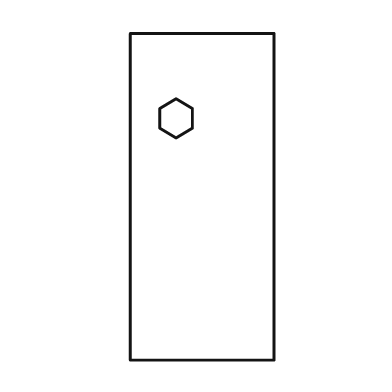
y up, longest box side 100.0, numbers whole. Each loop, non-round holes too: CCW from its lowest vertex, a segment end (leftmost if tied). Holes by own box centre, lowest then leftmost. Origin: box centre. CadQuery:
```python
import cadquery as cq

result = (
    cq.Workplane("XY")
    .moveTo(-22.0, -50.0)
    .lineTo(22.0, -50.0)
    .lineTo(22.0, 50.0)
    .lineTo(-22.0, 50.0)
    .close()
    .moveTo(-8.0, 18.0)
    .lineTo(-3.0, 21.0)
    .lineTo(-3.0, 27.0)
    .lineTo(-8.0, 30.0)
    .lineTo(-13.0, 27.0)
    .lineTo(-13.0, 21.0)
    .close()
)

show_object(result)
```